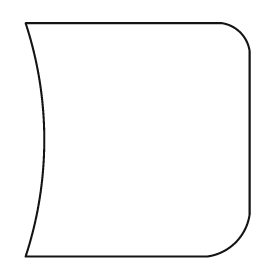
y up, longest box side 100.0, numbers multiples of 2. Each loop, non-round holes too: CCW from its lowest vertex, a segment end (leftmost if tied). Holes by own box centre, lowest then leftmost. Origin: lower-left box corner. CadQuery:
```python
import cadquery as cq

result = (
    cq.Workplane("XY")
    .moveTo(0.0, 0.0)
    .lineTo(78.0, 0.0)
    .threePointArc((90.0, 6.0), (96.0, 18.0))
    .lineTo(96.0, 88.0)
    .threePointArc((92.0, 96.0), (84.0, 100.0))
    .lineTo(0.0, 100.0)
    .threePointArc((8.0, 50.0), (0.0, 0.0))
    .close()
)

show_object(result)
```